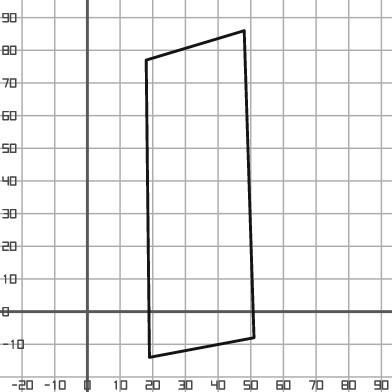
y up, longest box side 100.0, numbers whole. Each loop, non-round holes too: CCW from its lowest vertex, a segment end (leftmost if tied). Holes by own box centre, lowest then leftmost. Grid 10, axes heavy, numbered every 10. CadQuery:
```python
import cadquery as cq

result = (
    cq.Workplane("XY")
    .moveTo(19.0, -14.0)
    .lineTo(51.0, -8.0)
    .lineTo(48.0, 86.0)
    .lineTo(18.0, 77.0)
    .close()
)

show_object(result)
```